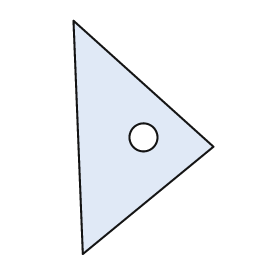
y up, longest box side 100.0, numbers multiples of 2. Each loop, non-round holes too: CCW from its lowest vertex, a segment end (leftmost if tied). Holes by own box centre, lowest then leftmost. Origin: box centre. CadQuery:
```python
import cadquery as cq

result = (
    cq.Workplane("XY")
    .moveTo(-26.0, -50.0)
    .lineTo(30.0, -4.0)
    .lineTo(-30.0, 50.0)
    .close()
    .moveTo(0.0, 0.0)
    .circle(6.0)
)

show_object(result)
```